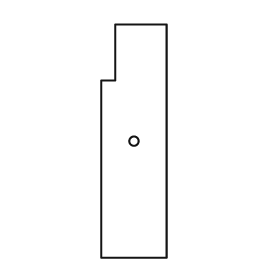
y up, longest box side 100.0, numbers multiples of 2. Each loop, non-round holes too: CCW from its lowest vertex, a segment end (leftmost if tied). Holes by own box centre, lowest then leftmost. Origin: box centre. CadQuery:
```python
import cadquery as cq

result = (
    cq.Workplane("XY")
    .moveTo(-14.0, -50.0)
    .lineTo(14.0, -50.0)
    .lineTo(14.0, 50.0)
    .lineTo(-8.0, 50.0)
    .lineTo(-8.0, 26.0)
    .lineTo(-14.0, 26.0)
    .close()
    .moveTo(0.0, 0.0)
    .circle(2.0)
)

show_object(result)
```